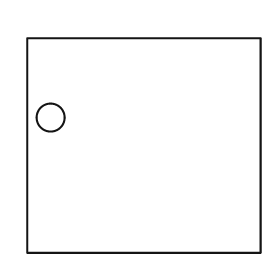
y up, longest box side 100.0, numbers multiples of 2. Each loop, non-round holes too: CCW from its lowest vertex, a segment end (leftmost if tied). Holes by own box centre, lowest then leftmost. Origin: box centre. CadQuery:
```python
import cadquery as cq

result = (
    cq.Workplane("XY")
    .moveTo(-50.0, -46.0)
    .lineTo(50.0, -46.0)
    .lineTo(50.0, 46.0)
    .lineTo(-50.0, 46.0)
    .close()
    .moveTo(-40.0, 12.0)
    .circle(6.0)
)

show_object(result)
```